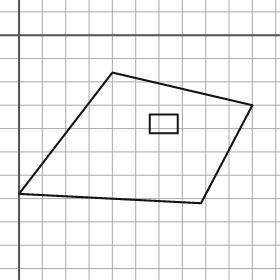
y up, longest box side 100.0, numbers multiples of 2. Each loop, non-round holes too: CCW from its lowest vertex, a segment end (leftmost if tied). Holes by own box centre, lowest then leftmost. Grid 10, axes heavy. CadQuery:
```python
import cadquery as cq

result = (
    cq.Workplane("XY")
    .moveTo(78.0, -72.0)
    .lineTo(100.0, -30.0)
    .lineTo(40.0, -16.0)
    .lineTo(0.0, -68.0)
    .close()
    .moveTo(56.0, -42.0)
    .lineTo(68.0, -42.0)
    .lineTo(68.0, -34.0)
    .lineTo(56.0, -34.0)
    .close()
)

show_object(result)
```